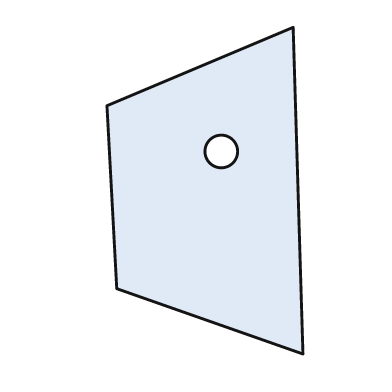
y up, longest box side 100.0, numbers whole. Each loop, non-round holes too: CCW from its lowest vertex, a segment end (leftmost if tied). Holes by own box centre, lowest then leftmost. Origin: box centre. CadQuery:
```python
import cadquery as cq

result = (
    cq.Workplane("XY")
    .moveTo(30.0, -50.0)
    .lineTo(27.0, 50.0)
    .lineTo(-30.0, 26.0)
    .lineTo(-27.0, -30.0)
    .close()
    .moveTo(5.0, 12.0)
    .circle(5.0)
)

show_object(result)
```